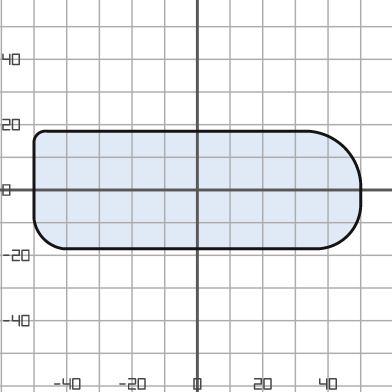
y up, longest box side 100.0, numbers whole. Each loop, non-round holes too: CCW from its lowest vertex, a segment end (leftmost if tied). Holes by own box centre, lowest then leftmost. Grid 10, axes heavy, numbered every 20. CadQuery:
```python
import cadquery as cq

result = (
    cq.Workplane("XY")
    .moveTo(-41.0, -18.0)
    .lineTo(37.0, -18.0)
    .threePointArc((46.0, -14.0), (50.0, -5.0))
    .lineTo(50.0, 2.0)
    .threePointArc((45.0, 13.0), (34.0, 18.0))
    .lineTo(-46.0, 18.0)
    .threePointArc((-49.0, 17.0), (-50.0, 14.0))
    .lineTo(-50.0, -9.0)
    .threePointArc((-47.0, -15.0), (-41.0, -18.0))
    .close()
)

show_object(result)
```